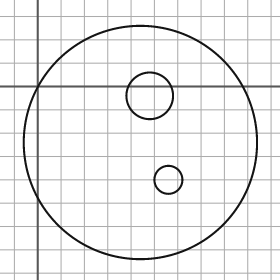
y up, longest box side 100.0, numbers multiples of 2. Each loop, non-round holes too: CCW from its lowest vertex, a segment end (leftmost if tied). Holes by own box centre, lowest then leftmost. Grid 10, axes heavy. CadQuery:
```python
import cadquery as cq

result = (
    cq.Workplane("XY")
    .moveTo(44.0, -24.0)
    .circle(50.0)
    .moveTo(56.0, -40.0)
    .circle(6.0)
    .moveTo(48.0, -4.0)
    .circle(10.0)
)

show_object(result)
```